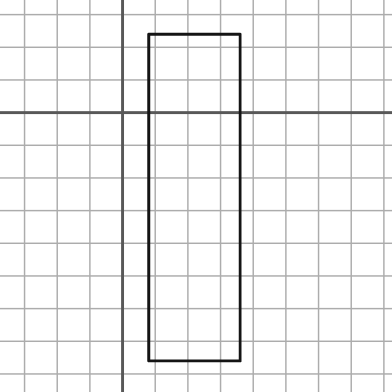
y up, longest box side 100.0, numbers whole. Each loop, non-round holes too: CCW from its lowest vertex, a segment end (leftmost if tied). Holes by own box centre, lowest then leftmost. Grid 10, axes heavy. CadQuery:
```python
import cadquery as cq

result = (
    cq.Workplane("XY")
    .moveTo(8.0, -76.0)
    .lineTo(36.0, -76.0)
    .lineTo(36.0, 24.0)
    .lineTo(8.0, 24.0)
    .close()
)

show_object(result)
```